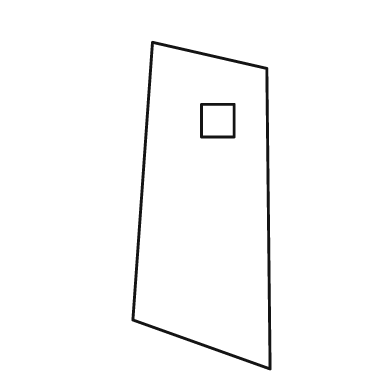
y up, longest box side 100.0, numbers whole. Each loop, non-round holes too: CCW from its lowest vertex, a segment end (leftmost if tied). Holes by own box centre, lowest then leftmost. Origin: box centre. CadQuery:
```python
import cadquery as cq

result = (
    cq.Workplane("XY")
    .moveTo(21.0, -50.0)
    .lineTo(20.0, 42.0)
    .lineTo(-15.0, 50.0)
    .lineTo(-21.0, -35.0)
    .close()
    .moveTo(0.0, 21.0)
    .lineTo(10.0, 21.0)
    .lineTo(10.0, 31.0)
    .lineTo(0.0, 31.0)
    .close()
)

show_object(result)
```